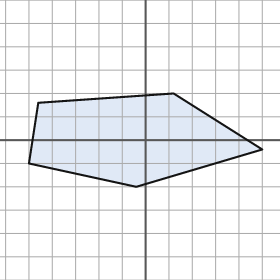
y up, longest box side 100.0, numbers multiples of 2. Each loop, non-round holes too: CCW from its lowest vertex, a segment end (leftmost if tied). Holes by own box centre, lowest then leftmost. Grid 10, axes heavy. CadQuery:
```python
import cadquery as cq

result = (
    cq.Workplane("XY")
    .moveTo(-4.0, -20.0)
    .lineTo(50.0, -4.0)
    .lineTo(12.0, 20.0)
    .lineTo(-46.0, 16.0)
    .lineTo(-50.0, -10.0)
    .close()
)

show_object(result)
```